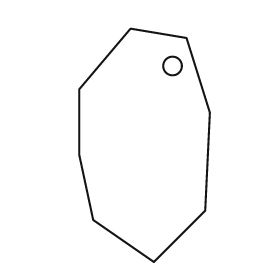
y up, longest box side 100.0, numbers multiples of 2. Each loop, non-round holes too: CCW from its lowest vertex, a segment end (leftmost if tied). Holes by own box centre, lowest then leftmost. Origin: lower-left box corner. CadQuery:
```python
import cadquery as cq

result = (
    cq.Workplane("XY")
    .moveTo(32.0, 0.0)
    .lineTo(54.0, 22.0)
    .lineTo(56.0, 64.0)
    .lineTo(46.0, 96.0)
    .lineTo(22.0, 100.0)
    .lineTo(0.0, 74.0)
    .lineTo(0.0, 46.0)
    .lineTo(6.0, 18.0)
    .close()
    .moveTo(40.0, 84.0)
    .circle(4.0)
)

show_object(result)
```